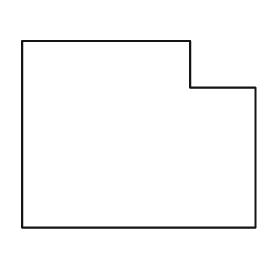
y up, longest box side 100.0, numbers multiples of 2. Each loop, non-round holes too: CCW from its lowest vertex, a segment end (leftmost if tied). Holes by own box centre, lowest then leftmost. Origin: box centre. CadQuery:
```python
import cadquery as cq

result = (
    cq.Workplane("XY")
    .moveTo(-50.0, -40.0)
    .lineTo(50.0, -40.0)
    .lineTo(50.0, 20.0)
    .lineTo(22.0, 20.0)
    .lineTo(22.0, 40.0)
    .lineTo(-50.0, 40.0)
    .close()
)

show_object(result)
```